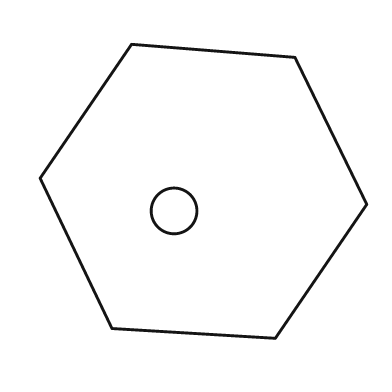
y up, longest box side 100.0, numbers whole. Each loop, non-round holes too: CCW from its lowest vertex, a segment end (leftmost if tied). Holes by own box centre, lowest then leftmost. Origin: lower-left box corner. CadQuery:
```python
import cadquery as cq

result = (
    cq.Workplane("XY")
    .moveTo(72.0, 0.0)
    .lineTo(100.0, 41.0)
    .lineTo(78.0, 86.0)
    .lineTo(28.0, 90.0)
    .lineTo(0.0, 49.0)
    .lineTo(22.0, 3.0)
    .close()
    .moveTo(41.0, 39.0)
    .circle(7.0)
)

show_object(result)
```